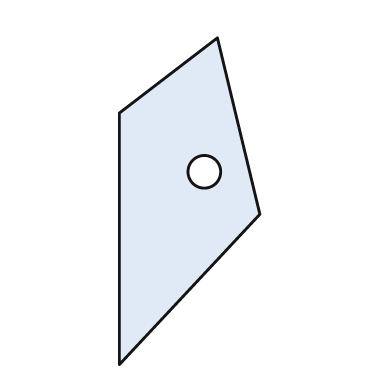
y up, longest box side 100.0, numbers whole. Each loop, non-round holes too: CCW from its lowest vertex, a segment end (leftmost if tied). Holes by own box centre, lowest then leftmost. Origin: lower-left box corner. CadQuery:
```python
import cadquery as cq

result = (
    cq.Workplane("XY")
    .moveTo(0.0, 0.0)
    .lineTo(43.0, 46.0)
    .lineTo(30.0, 100.0)
    .lineTo(0.0, 77.0)
    .close()
    .moveTo(26.0, 59.0)
    .circle(5.0)
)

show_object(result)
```